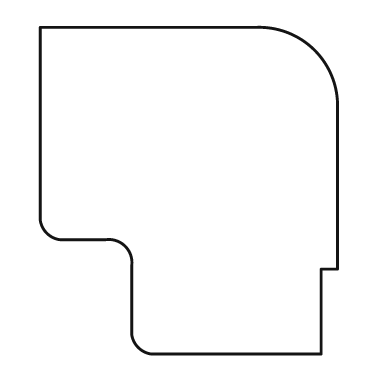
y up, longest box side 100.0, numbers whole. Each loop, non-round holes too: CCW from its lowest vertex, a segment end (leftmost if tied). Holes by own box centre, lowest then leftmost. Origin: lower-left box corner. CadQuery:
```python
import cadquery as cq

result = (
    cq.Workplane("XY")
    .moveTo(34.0, 0.0)
    .lineTo(86.0, 0.0)
    .lineTo(86.0, 26.0)
    .lineTo(91.0, 26.0)
    .lineTo(91.0, 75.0)
    .threePointArc((84.0, 93.0), (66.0, 100.0))
    .lineTo(0.0, 100.0)
    .lineTo(0.0, 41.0)
    .threePointArc((2.0, 37.0), (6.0, 35.0))
    .lineTo(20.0, 35.0)
    .threePointArc((26.0, 33.0), (28.0, 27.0))
    .lineTo(28.0, 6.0)
    .threePointArc((30.0, 2.0), (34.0, 0.0))
    .close()
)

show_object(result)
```